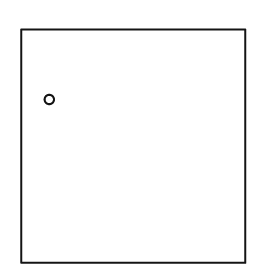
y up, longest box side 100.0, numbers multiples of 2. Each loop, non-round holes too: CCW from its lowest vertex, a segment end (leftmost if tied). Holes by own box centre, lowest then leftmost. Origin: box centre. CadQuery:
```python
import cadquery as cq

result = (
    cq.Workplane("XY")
    .moveTo(-48.0, -50.0)
    .lineTo(48.0, -50.0)
    .lineTo(48.0, 50.0)
    .lineTo(-48.0, 50.0)
    .close()
    .moveTo(-36.0, 20.0)
    .circle(2.0)
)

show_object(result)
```